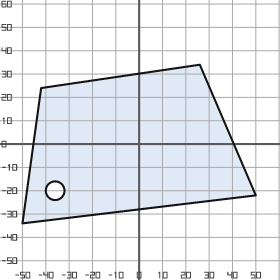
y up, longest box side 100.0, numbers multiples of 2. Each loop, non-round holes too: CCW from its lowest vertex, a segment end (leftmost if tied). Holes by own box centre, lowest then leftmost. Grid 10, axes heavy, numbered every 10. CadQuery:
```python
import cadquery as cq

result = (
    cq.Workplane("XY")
    .moveTo(-50.0, -34.0)
    .lineTo(50.0, -22.0)
    .lineTo(26.0, 34.0)
    .lineTo(-42.0, 24.0)
    .close()
    .moveTo(-36.0, -20.0)
    .circle(4.0)
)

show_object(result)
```